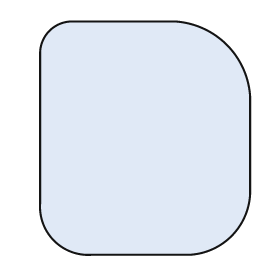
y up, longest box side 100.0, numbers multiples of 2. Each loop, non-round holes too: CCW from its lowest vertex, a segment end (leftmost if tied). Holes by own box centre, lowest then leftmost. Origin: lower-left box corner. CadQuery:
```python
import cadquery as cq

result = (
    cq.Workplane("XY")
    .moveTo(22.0, 0.0)
    .lineTo(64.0, 0.0)
    .threePointArc((82.0, 8.0), (90.0, 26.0))
    .lineTo(90.0, 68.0)
    .threePointArc((80.0, 90.0), (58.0, 100.0))
    .lineTo(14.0, 100.0)
    .threePointArc((4.0, 96.0), (0.0, 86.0))
    .lineTo(0.0, 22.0)
    .threePointArc((6.0, 6.0), (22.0, 0.0))
    .close()
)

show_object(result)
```